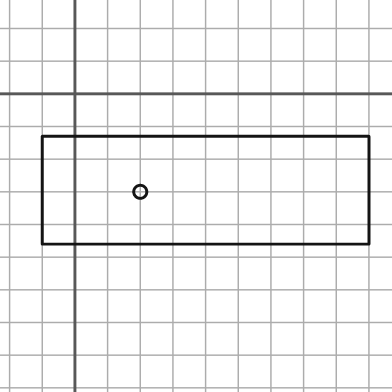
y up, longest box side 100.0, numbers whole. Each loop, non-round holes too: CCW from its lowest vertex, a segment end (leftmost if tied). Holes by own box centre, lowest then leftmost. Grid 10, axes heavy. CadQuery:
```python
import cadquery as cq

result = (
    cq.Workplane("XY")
    .moveTo(-10.0, -46.0)
    .lineTo(90.0, -46.0)
    .lineTo(90.0, -13.0)
    .lineTo(-10.0, -13.0)
    .close()
    .moveTo(20.0, -30.0)
    .circle(2.0)
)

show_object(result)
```